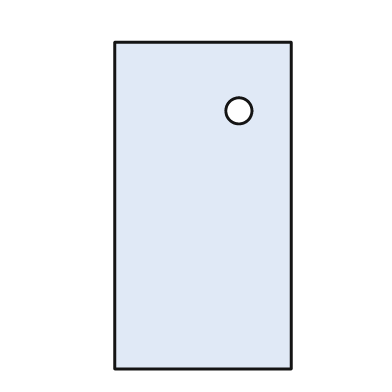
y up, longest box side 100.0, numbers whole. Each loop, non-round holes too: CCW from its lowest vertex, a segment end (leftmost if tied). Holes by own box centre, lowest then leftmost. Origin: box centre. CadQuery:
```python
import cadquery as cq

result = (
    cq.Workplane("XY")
    .moveTo(-27.0, -50.0)
    .lineTo(27.0, -50.0)
    .lineTo(27.0, 50.0)
    .lineTo(-27.0, 50.0)
    .close()
    .moveTo(11.0, 29.0)
    .circle(4.0)
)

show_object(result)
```